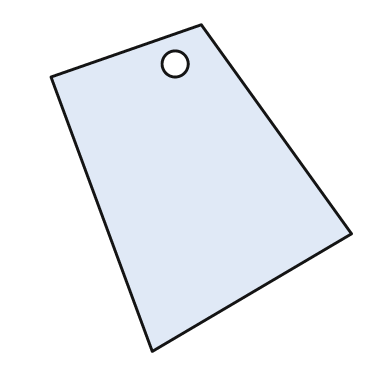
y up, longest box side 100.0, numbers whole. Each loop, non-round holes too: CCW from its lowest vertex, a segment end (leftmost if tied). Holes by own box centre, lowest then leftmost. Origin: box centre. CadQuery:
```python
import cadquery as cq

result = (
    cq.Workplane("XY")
    .moveTo(-15.0, -50.0)
    .lineTo(46.0, -14.0)
    .lineTo(0.0, 50.0)
    .lineTo(-46.0, 34.0)
    .close()
    .moveTo(-8.0, 38.0)
    .circle(4.0)
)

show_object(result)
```